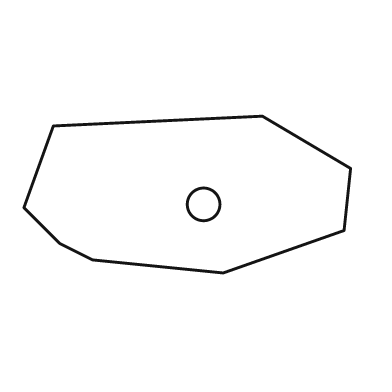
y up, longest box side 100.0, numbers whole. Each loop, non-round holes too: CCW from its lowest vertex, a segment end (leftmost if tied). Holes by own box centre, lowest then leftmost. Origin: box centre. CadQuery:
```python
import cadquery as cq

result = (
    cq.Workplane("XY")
    .moveTo(11.0, -24.0)
    .lineTo(48.0, -11.0)
    .lineTo(50.0, 8.0)
    .lineTo(23.0, 24.0)
    .lineTo(-41.0, 21.0)
    .lineTo(-50.0, -4.0)
    .lineTo(-39.0, -15.0)
    .lineTo(-29.0, -20.0)
    .close()
    .moveTo(5.0, -3.0)
    .circle(5.0)
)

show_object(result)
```